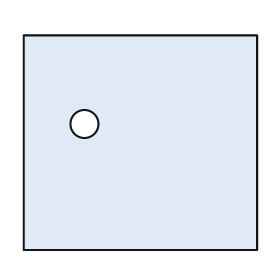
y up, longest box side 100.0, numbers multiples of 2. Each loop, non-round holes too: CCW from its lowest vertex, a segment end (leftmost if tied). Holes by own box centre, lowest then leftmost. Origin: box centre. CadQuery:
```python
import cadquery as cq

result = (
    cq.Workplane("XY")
    .moveTo(-50.0, -46.0)
    .lineTo(50.0, -46.0)
    .lineTo(50.0, 46.0)
    .lineTo(-50.0, 46.0)
    .close()
    .moveTo(-24.0, 8.0)
    .circle(6.0)
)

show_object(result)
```